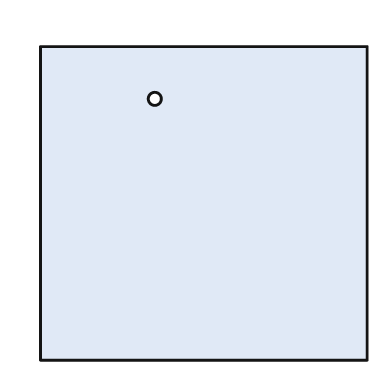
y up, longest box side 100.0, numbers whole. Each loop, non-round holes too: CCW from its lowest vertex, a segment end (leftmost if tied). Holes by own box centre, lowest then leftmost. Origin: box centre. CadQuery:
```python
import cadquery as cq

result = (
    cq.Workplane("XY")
    .moveTo(-50.0, -48.0)
    .lineTo(50.0, -48.0)
    .lineTo(50.0, 48.0)
    .lineTo(-50.0, 48.0)
    .close()
    .moveTo(-15.0, 32.0)
    .circle(2.0)
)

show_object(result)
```